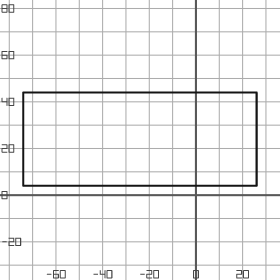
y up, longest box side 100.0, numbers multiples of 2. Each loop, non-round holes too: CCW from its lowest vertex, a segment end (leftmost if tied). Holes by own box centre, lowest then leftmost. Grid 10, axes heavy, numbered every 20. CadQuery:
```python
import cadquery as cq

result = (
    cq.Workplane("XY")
    .moveTo(-74.0, 4.0)
    .lineTo(26.0, 4.0)
    .lineTo(26.0, 44.0)
    .lineTo(-74.0, 44.0)
    .close()
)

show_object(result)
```